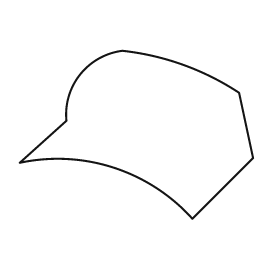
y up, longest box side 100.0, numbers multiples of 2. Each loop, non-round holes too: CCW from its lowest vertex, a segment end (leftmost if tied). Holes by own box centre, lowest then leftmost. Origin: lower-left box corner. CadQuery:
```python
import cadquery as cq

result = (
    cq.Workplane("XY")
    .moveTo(74.0, 0.0)
    .lineTo(100.0, 26.0)
    .lineTo(94.0, 54.0)
    .threePointArc((70.0, 66.0), (44.0, 72.0))
    .threePointArc((26.0, 62.0), (20.0, 42.0))
    .lineTo(0.0, 24.0)
    .threePointArc((40.0, 22.0), (74.0, 0.0))
    .close()
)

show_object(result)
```